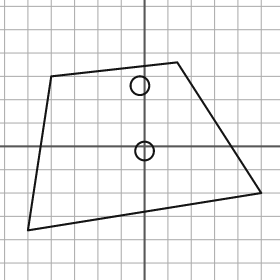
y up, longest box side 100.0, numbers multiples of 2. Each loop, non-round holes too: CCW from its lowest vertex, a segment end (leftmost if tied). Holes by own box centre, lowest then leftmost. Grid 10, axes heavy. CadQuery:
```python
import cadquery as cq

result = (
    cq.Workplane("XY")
    .moveTo(-50.0, -36.0)
    .lineTo(50.0, -20.0)
    .lineTo(14.0, 36.0)
    .lineTo(-40.0, 30.0)
    .close()
    .moveTo(0.0, -2.0)
    .circle(4.0)
    .moveTo(-2.0, 26.0)
    .circle(4.0)
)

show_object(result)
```